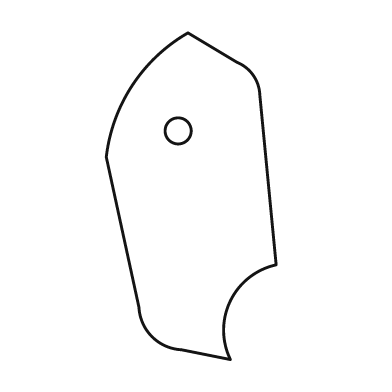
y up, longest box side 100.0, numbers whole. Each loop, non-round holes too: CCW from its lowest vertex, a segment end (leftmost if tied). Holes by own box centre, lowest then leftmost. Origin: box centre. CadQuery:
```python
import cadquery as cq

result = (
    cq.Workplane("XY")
    .moveTo(12.0, -50.0)
    .threePointArc((12.0, -32.0), (26.0, -21.0))
    .lineTo(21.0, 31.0)
    .threePointArc((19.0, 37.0), (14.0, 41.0))
    .lineTo(-1.0, 50.0)
    .threePointArc((-18.0, 34.0), (-26.0, 12.0))
    .lineTo(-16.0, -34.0)
    .threePointArc((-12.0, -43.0), (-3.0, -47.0))
    .close()
    .moveTo(-4.0, 20.0)
    .circle(4.0)
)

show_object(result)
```